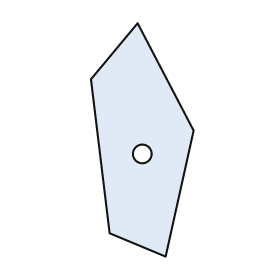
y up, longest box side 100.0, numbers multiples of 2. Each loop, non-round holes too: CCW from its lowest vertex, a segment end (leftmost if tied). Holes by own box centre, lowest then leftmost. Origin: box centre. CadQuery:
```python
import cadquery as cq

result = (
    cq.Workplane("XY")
    .moveTo(10.0, -50.0)
    .lineTo(22.0, 4.0)
    .lineTo(-2.0, 50.0)
    .lineTo(-22.0, 26.0)
    .lineTo(-14.0, -40.0)
    .close()
    .moveTo(0.0, -6.0)
    .circle(4.0)
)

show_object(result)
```